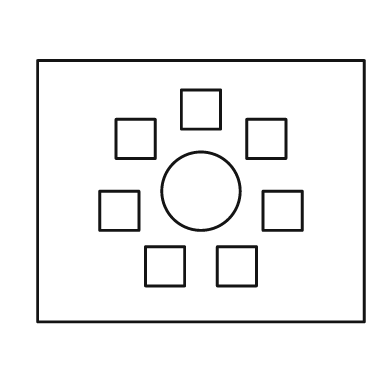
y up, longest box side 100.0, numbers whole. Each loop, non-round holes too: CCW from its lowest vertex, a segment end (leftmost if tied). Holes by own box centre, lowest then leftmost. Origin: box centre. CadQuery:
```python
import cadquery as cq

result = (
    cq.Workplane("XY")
    .moveTo(-50.0, -40.0)
    .lineTo(50.0, -40.0)
    .lineTo(50.0, 40.0)
    .lineTo(-50.0, 40.0)
    .close()
    .moveTo(-17.0, -29.0)
    .lineTo(-5.0, -29.0)
    .lineTo(-5.0, -17.0)
    .lineTo(-17.0, -17.0)
    .close()
    .moveTo(5.0, -29.0)
    .lineTo(17.0, -29.0)
    .lineTo(17.0, -17.0)
    .lineTo(5.0, -17.0)
    .close()
    .moveTo(-31.0, -12.0)
    .lineTo(-19.0, -12.0)
    .lineTo(-19.0, 0.0)
    .lineTo(-31.0, 0.0)
    .close()
    .moveTo(19.0, -12.0)
    .lineTo(31.0, -12.0)
    .lineTo(31.0, 0.0)
    .lineTo(19.0, 0.0)
    .close()
    .moveTo(0.0, 0.0)
    .circle(12.0)
    .moveTo(-26.0, 10.0)
    .lineTo(-14.0, 10.0)
    .lineTo(-14.0, 22.0)
    .lineTo(-26.0, 22.0)
    .close()
    .moveTo(14.0, 10.0)
    .lineTo(26.0, 10.0)
    .lineTo(26.0, 22.0)
    .lineTo(14.0, 22.0)
    .close()
    .moveTo(-6.0, 19.0)
    .lineTo(6.0, 19.0)
    .lineTo(6.0, 31.0)
    .lineTo(-6.0, 31.0)
    .close()
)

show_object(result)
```